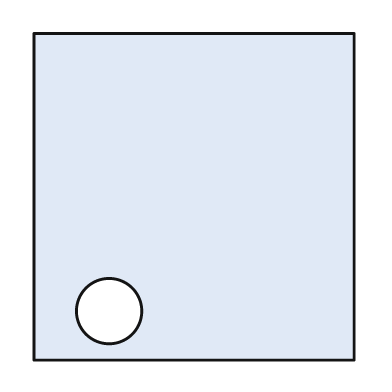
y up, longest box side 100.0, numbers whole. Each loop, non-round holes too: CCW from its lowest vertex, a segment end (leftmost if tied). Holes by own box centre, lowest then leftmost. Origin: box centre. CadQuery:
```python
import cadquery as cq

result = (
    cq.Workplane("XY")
    .moveTo(-49.0, -50.0)
    .lineTo(49.0, -50.0)
    .lineTo(49.0, 50.0)
    .lineTo(-49.0, 50.0)
    .close()
    .moveTo(-26.0, -35.0)
    .circle(10.0)
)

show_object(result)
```